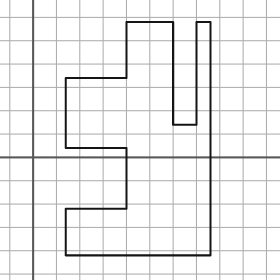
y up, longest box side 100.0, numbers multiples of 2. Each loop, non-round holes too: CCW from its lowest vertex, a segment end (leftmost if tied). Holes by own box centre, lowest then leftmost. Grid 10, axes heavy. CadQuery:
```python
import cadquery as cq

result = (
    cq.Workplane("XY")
    .moveTo(14.0, -42.0)
    .lineTo(76.0, -42.0)
    .lineTo(76.0, 58.0)
    .lineTo(70.0, 58.0)
    .lineTo(70.0, 14.0)
    .lineTo(60.0, 14.0)
    .lineTo(60.0, 58.0)
    .lineTo(40.0, 58.0)
    .lineTo(40.0, 34.0)
    .lineTo(14.0, 34.0)
    .lineTo(14.0, 4.0)
    .lineTo(40.0, 4.0)
    .lineTo(40.0, -22.0)
    .lineTo(14.0, -22.0)
    .close()
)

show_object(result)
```